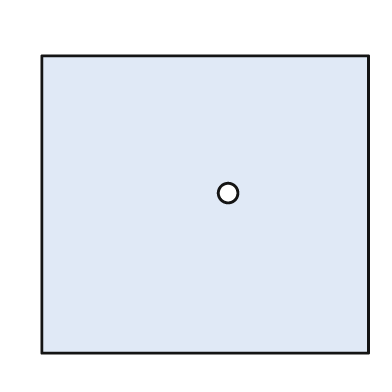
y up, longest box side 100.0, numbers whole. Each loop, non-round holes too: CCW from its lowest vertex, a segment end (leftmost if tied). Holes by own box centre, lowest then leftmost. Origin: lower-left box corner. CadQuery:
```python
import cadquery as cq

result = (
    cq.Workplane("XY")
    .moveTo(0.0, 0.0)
    .lineTo(100.0, 0.0)
    .lineTo(100.0, 91.0)
    .lineTo(0.0, 91.0)
    .close()
    .moveTo(57.0, 49.0)
    .circle(3.0)
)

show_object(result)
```